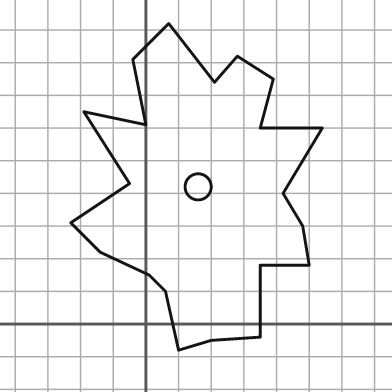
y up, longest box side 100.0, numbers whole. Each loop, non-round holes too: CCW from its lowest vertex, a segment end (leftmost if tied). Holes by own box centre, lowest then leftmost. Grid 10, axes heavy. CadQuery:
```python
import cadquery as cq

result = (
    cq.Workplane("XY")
    .moveTo(10.0, -8.0)
    .lineTo(20.0, -5.0)
    .lineTo(35.0, -4.0)
    .lineTo(35.0, 18.0)
    .lineTo(50.0, 18.0)
    .lineTo(48.0, 30.0)
    .lineTo(42.0, 40.0)
    .lineTo(54.0, 60.0)
    .lineTo(35.0, 60.0)
    .lineTo(39.0, 75.0)
    .lineTo(28.0, 82.0)
    .lineTo(21.0, 74.0)
    .lineTo(7.0, 92.0)
    .lineTo(-4.0, 81.0)
    .lineTo(0.0, 61.0)
    .lineTo(-19.0, 65.0)
    .lineTo(-5.0, 43.0)
    .lineTo(-23.0, 31.0)
    .lineTo(-14.0, 22.0)
    .lineTo(1.0, 15.0)
    .lineTo(6.0, 10.0)
    .close()
    .moveTo(16.0, 42.0)
    .circle(4.0)
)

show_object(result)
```